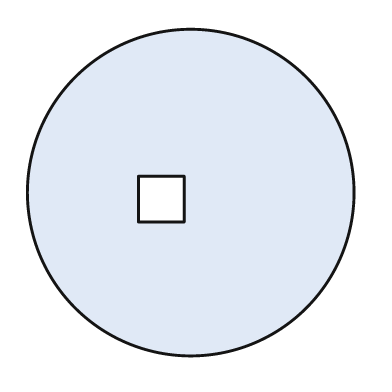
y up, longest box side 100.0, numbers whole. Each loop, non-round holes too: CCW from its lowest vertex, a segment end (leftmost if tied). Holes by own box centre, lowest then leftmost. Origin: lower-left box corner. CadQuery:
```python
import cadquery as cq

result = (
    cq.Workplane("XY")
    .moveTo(50.0, 50.0)
    .circle(50.0)
    .moveTo(34.0, 41.0)
    .lineTo(48.0, 41.0)
    .lineTo(48.0, 55.0)
    .lineTo(34.0, 55.0)
    .close()
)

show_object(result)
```